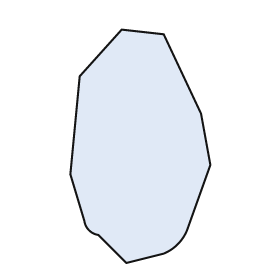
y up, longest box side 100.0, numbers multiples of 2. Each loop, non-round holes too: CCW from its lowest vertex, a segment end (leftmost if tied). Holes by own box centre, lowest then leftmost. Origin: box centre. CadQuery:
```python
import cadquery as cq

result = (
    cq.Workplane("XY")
    .moveTo(-6.0, -50.0)
    .lineTo(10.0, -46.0)
    .threePointArc((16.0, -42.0), (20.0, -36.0))
    .lineTo(30.0, -8.0)
    .lineTo(26.0, 14.0)
    .lineTo(10.0, 48.0)
    .lineTo(-8.0, 50.0)
    .lineTo(-26.0, 30.0)
    .lineTo(-30.0, -12.0)
    .lineTo(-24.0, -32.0)
    .threePointArc((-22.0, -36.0), (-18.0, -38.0))
    .close()
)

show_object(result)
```